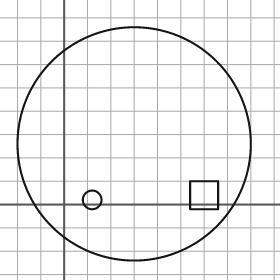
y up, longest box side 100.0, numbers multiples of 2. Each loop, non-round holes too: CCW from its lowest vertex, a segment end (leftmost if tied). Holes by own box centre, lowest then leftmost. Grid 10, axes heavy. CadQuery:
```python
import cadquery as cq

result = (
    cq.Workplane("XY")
    .moveTo(30.0, 26.0)
    .circle(50.0)
    .moveTo(12.0, 2.0)
    .circle(4.0)
    .moveTo(54.0, -2.0)
    .lineTo(66.0, -2.0)
    .lineTo(66.0, 10.0)
    .lineTo(54.0, 10.0)
    .close()
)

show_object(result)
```